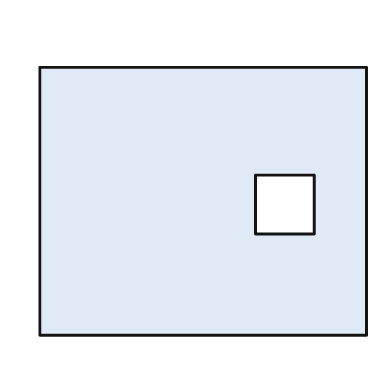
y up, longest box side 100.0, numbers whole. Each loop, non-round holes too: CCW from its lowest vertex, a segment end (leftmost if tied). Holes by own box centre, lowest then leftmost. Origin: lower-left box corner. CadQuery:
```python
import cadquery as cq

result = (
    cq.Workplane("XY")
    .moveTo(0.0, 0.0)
    .lineTo(100.0, 0.0)
    .lineTo(100.0, 82.0)
    .lineTo(0.0, 82.0)
    .close()
    .moveTo(66.0, 31.0)
    .lineTo(84.0, 31.0)
    .lineTo(84.0, 49.0)
    .lineTo(66.0, 49.0)
    .close()
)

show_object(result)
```